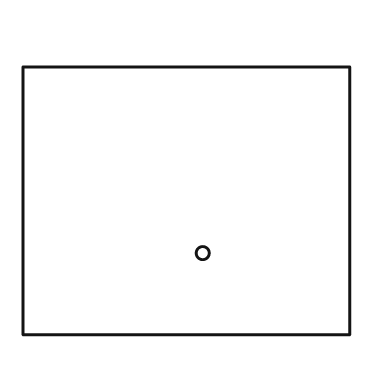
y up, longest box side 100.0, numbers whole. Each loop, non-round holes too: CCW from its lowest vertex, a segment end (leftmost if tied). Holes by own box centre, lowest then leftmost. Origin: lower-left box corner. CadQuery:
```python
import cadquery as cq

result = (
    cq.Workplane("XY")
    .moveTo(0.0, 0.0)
    .lineTo(100.0, 0.0)
    .lineTo(100.0, 82.0)
    .lineTo(0.0, 82.0)
    .close()
    .moveTo(55.0, 25.0)
    .circle(2.0)
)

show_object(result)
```